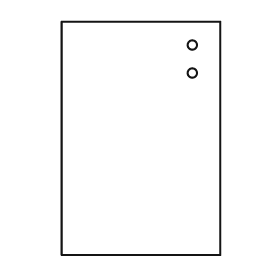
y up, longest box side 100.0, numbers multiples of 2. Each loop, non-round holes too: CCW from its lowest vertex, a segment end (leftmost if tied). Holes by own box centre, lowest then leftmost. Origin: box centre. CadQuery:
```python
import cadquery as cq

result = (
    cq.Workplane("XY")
    .moveTo(-34.0, -50.0)
    .lineTo(34.0, -50.0)
    .lineTo(34.0, 50.0)
    .lineTo(-34.0, 50.0)
    .close()
    .moveTo(22.0, 28.0)
    .circle(2.0)
    .moveTo(22.0, 40.0)
    .circle(2.0)
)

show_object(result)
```